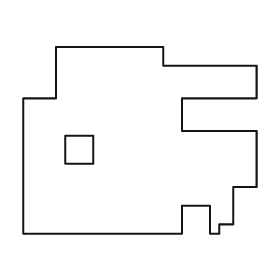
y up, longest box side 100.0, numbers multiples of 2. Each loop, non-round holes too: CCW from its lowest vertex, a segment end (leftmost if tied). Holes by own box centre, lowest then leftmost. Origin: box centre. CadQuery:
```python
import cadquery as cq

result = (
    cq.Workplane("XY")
    .moveTo(-50.0, -40.0)
    .lineTo(18.0, -40.0)
    .lineTo(18.0, -28.0)
    .lineTo(30.0, -28.0)
    .lineTo(30.0, -40.0)
    .lineTo(34.0, -40.0)
    .lineTo(34.0, -36.0)
    .lineTo(40.0, -36.0)
    .lineTo(40.0, -20.0)
    .lineTo(50.0, -20.0)
    .lineTo(50.0, 4.0)
    .lineTo(18.0, 4.0)
    .lineTo(18.0, 18.0)
    .lineTo(50.0, 18.0)
    .lineTo(50.0, 32.0)
    .lineTo(10.0, 32.0)
    .lineTo(10.0, 40.0)
    .lineTo(-36.0, 40.0)
    .lineTo(-36.0, 18.0)
    .lineTo(-50.0, 18.0)
    .close()
    .moveTo(-32.0, -10.0)
    .lineTo(-20.0, -10.0)
    .lineTo(-20.0, 2.0)
    .lineTo(-32.0, 2.0)
    .close()
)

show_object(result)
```